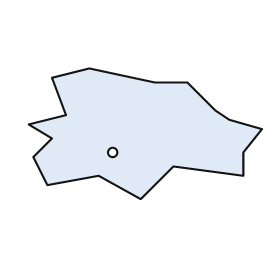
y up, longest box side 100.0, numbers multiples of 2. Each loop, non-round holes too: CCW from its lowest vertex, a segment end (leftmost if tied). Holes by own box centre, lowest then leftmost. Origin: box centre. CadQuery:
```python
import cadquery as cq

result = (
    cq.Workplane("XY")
    .moveTo(-2.0, -28.0)
    .lineTo(12.0, -14.0)
    .lineTo(42.0, -18.0)
    .lineTo(42.0, -8.0)
    .lineTo(50.0, 2.0)
    .lineTo(36.0, 6.0)
    .lineTo(30.0, 10.0)
    .lineTo(18.0, 22.0)
    .lineTo(4.0, 22.0)
    .lineTo(-24.0, 28.0)
    .lineTo(-40.0, 24.0)
    .lineTo(-34.0, 8.0)
    .lineTo(-50.0, 4.0)
    .lineTo(-40.0, -2.0)
    .lineTo(-48.0, -10.0)
    .lineTo(-42.0, -22.0)
    .lineTo(-20.0, -18.0)
    .close()
    .moveTo(-14.0, -8.0)
    .circle(2.0)
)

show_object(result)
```